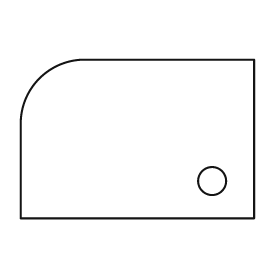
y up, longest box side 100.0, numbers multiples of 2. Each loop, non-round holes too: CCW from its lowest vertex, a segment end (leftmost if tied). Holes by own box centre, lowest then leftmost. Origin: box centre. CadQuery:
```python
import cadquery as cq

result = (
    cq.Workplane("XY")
    .moveTo(-50.0, -34.0)
    .lineTo(50.0, -34.0)
    .lineTo(50.0, 34.0)
    .lineTo(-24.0, 34.0)
    .threePointArc((-42.0, 26.0), (-50.0, 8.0))
    .close()
    .moveTo(32.0, -18.0)
    .circle(6.0)
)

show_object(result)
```